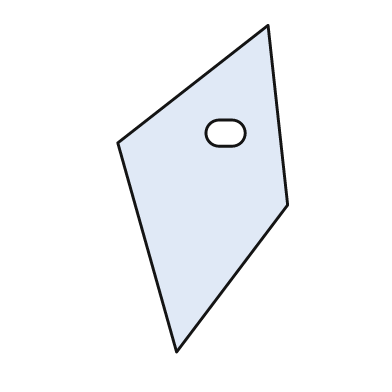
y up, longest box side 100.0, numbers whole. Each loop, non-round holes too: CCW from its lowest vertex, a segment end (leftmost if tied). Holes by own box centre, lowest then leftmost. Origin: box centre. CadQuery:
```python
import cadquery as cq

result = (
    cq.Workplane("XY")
    .moveTo(-8.0, -50.0)
    .lineTo(26.0, -5.0)
    .lineTo(20.0, 50.0)
    .lineTo(-26.0, 14.0)
    .close()
    .moveTo(5.0, 13.0)
    .lineTo(9.0, 13.0)
    .threePointArc((13.0, 17.0), (9.0, 21.0))
    .lineTo(5.0, 21.0)
    .threePointArc((1.0, 17.0), (5.0, 13.0))
    .close()
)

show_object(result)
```